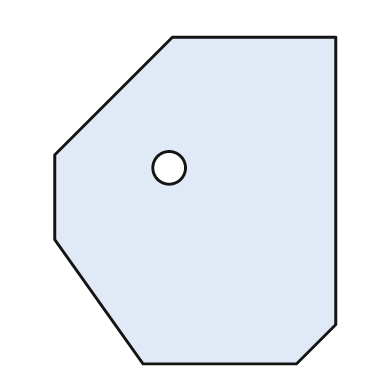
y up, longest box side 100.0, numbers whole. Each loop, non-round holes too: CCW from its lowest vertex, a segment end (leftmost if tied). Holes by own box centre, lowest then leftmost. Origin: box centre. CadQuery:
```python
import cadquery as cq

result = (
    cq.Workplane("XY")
    .moveTo(-16.0, -50.0)
    .lineTo(31.0, -50.0)
    .lineTo(43.0, -38.0)
    .lineTo(43.0, 50.0)
    .lineTo(-7.0, 50.0)
    .lineTo(-43.0, 14.0)
    .lineTo(-43.0, -12.0)
    .close()
    .moveTo(-8.0, 10.0)
    .circle(5.0)
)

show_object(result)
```